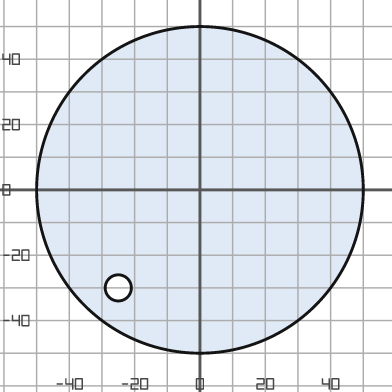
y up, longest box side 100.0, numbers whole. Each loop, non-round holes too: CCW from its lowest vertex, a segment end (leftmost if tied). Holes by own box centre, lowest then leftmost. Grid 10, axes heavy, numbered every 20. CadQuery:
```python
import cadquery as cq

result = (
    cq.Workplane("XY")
    .moveTo(0.0, 0.0)
    .circle(50.0)
    .moveTo(-25.0, -30.0)
    .circle(4.0)
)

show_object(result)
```